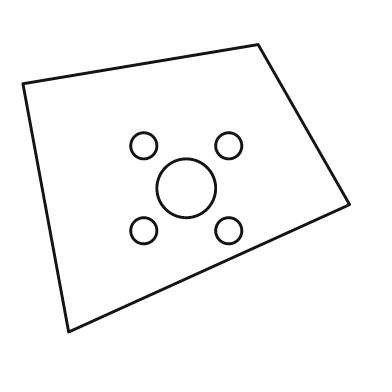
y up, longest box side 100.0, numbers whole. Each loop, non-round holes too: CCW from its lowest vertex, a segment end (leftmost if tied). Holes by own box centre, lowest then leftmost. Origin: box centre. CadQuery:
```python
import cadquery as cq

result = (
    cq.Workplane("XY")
    .moveTo(-36.0, -44.0)
    .lineTo(50.0, -5.0)
    .lineTo(22.0, 44.0)
    .lineTo(-50.0, 32.0)
    .close()
    .moveTo(-13.0, -13.0)
    .circle(4.0)
    .moveTo(13.0, -13.0)
    .circle(4.0)
    .moveTo(0.0, 0.0)
    .circle(9.0)
    .moveTo(-13.0, 13.0)
    .circle(4.0)
    .moveTo(13.0, 13.0)
    .circle(4.0)
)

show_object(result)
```